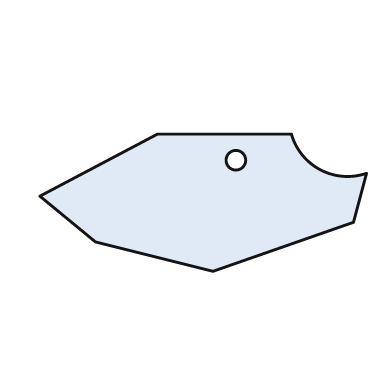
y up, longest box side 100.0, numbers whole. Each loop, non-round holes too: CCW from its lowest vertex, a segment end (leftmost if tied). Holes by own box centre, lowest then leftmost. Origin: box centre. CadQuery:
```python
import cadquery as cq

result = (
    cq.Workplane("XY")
    .moveTo(3.0, -21.0)
    .lineTo(46.0, -6.0)
    .lineTo(50.0, 9.0)
    .threePointArc((36.0, 10.0), (27.0, 21.0))
    .lineTo(-14.0, 21.0)
    .lineTo(-50.0, 2.0)
    .lineTo(-33.0, -12.0)
    .close()
    .moveTo(10.0, 13.0)
    .circle(3.0)
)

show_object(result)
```